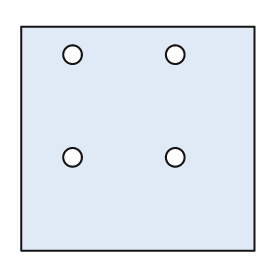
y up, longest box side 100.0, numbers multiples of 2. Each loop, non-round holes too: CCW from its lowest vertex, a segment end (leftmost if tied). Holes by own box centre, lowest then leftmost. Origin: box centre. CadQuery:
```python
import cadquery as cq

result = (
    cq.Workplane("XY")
    .moveTo(-50.0, -48.0)
    .lineTo(50.0, -48.0)
    .lineTo(50.0, 48.0)
    .lineTo(-50.0, 48.0)
    .close()
    .moveTo(-28.0, -8.0)
    .circle(4.0)
    .moveTo(16.0, -8.0)
    .circle(4.0)
    .moveTo(-28.0, 36.0)
    .circle(4.0)
    .moveTo(16.0, 36.0)
    .circle(4.0)
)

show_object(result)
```